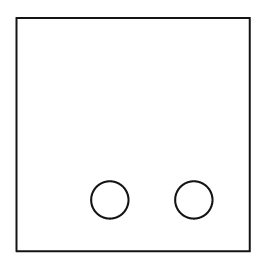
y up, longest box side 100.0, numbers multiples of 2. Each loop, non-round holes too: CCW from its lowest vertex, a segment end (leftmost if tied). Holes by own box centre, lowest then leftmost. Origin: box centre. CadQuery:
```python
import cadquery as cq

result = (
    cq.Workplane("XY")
    .moveTo(-50.0, -50.0)
    .lineTo(50.0, -50.0)
    .lineTo(50.0, 50.0)
    .lineTo(-50.0, 50.0)
    .close()
    .moveTo(-10.0, -28.0)
    .circle(8.0)
    .moveTo(26.0, -28.0)
    .circle(8.0)
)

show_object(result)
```